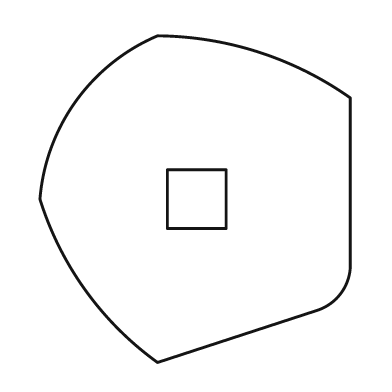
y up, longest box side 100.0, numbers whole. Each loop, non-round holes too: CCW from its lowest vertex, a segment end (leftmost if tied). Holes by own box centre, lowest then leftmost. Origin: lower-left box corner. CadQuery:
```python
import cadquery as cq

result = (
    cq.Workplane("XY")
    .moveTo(36.0, 0.0)
    .lineTo(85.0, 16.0)
    .threePointArc((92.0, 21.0), (95.0, 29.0))
    .lineTo(95.0, 81.0)
    .threePointArc((67.0, 95.0), (36.0, 100.0))
    .threePointArc((11.0, 80.0), (0.0, 50.0))
    .threePointArc((14.0, 22.0), (36.0, 0.0))
    .close()
    .moveTo(39.0, 41.0)
    .lineTo(57.0, 41.0)
    .lineTo(57.0, 59.0)
    .lineTo(39.0, 59.0)
    .close()
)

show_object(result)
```